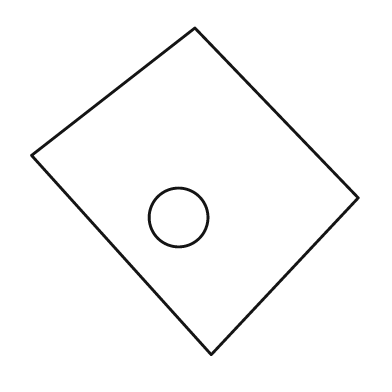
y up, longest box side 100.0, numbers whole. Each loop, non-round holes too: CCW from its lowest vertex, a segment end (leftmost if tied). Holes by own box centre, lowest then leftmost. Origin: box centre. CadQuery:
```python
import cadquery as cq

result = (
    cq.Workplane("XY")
    .moveTo(5.0, -50.0)
    .lineTo(50.0, -2.0)
    .lineTo(0.0, 50.0)
    .lineTo(-50.0, 11.0)
    .close()
    .moveTo(-5.0, -8.0)
    .circle(9.0)
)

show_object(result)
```